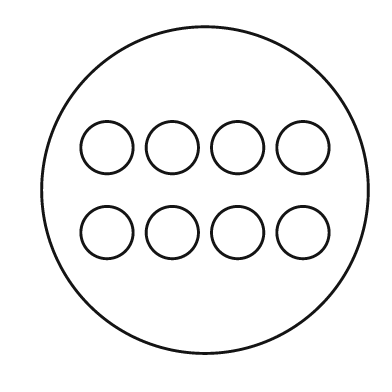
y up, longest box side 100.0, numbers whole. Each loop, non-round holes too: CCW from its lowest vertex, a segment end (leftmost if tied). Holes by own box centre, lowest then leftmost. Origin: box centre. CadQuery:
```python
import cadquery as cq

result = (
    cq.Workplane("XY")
    .moveTo(0.0, 0.0)
    .circle(50.0)
    .moveTo(-30.0, -13.0)
    .circle(8.0)
    .moveTo(-10.0, -13.0)
    .circle(8.0)
    .moveTo(10.0, -13.0)
    .circle(8.0)
    .moveTo(30.0, -13.0)
    .circle(8.0)
    .moveTo(-30.0, 13.0)
    .circle(8.0)
    .moveTo(-10.0, 13.0)
    .circle(8.0)
    .moveTo(10.0, 13.0)
    .circle(8.0)
    .moveTo(30.0, 13.0)
    .circle(8.0)
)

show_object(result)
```